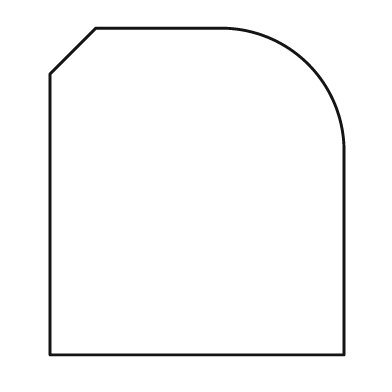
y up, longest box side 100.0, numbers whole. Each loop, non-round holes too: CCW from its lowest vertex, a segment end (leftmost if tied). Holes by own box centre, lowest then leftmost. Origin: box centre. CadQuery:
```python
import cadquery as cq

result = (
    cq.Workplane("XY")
    .moveTo(-45.0, -50.0)
    .lineTo(45.0, -50.0)
    .lineTo(45.0, 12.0)
    .threePointArc((34.0, 39.0), (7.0, 50.0))
    .lineTo(-31.0, 50.0)
    .lineTo(-45.0, 36.0)
    .close()
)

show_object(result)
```